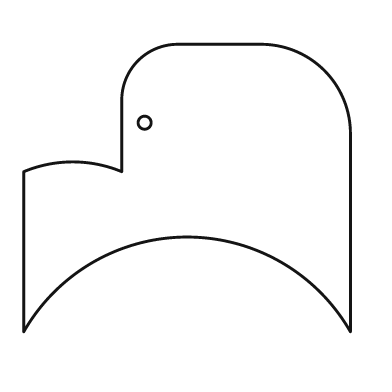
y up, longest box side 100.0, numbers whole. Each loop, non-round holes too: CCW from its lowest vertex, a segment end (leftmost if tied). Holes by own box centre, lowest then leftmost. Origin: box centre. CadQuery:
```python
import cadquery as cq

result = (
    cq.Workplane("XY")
    .moveTo(-50.0, -44.0)
    .threePointArc((0.0, -15.0), (50.0, -44.0))
    .lineTo(50.0, 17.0)
    .threePointArc((42.0, 36.0), (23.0, 44.0))
    .lineTo(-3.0, 44.0)
    .threePointArc((-15.0, 39.0), (-20.0, 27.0))
    .lineTo(-20.0, 5.0)
    .threePointArc((-35.0, 8.0), (-50.0, 5.0))
    .close()
    .moveTo(-13.0, 20.0)
    .circle(2.0)
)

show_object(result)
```